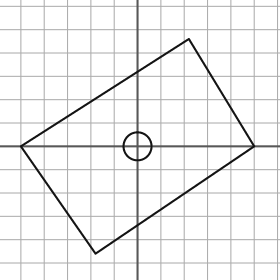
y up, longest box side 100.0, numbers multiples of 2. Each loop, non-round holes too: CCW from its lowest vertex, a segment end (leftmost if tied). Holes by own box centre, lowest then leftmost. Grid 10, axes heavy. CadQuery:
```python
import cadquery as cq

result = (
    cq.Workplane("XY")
    .moveTo(-18.0, -46.0)
    .lineTo(50.0, 0.0)
    .lineTo(22.0, 46.0)
    .lineTo(-50.0, 0.0)
    .close()
    .moveTo(0.0, 0.0)
    .circle(6.0)
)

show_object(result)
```